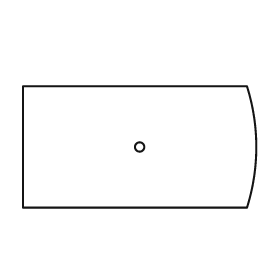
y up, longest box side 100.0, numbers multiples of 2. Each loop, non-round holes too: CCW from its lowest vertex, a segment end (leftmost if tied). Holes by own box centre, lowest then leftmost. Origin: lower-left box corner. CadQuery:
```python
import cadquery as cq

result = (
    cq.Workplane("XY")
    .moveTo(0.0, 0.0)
    .lineTo(96.0, 0.0)
    .threePointArc((100.0, 26.0), (96.0, 52.0))
    .lineTo(0.0, 52.0)
    .close()
    .moveTo(50.0, 26.0)
    .circle(2.0)
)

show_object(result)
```